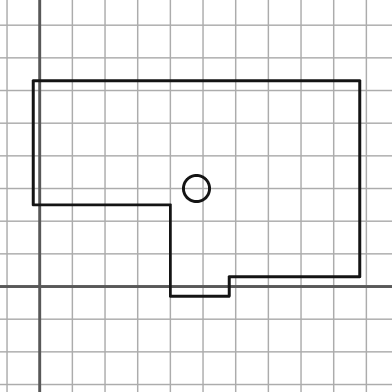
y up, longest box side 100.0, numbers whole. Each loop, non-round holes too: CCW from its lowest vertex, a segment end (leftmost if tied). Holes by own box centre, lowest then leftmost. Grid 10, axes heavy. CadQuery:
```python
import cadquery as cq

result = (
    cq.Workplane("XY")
    .moveTo(40.0, -3.0)
    .lineTo(58.0, -3.0)
    .lineTo(58.0, 3.0)
    .lineTo(98.0, 3.0)
    .lineTo(98.0, 63.0)
    .lineTo(-2.0, 63.0)
    .lineTo(-2.0, 25.0)
    .lineTo(40.0, 25.0)
    .close()
    .moveTo(48.0, 30.0)
    .circle(4.0)
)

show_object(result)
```